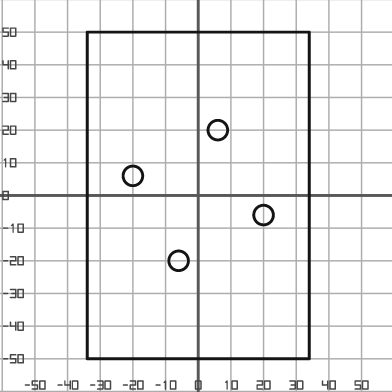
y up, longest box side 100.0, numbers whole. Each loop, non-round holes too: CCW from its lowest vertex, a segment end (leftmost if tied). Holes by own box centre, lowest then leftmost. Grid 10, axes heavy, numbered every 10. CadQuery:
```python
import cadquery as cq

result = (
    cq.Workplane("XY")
    .moveTo(-34.0, -50.0)
    .lineTo(34.0, -50.0)
    .lineTo(34.0, 50.0)
    .lineTo(-34.0, 50.0)
    .close()
    .moveTo(-6.0, -20.0)
    .circle(3.0)
    .moveTo(20.0, -6.0)
    .circle(3.0)
    .moveTo(-20.0, 6.0)
    .circle(3.0)
    .moveTo(6.0, 20.0)
    .circle(3.0)
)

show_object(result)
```